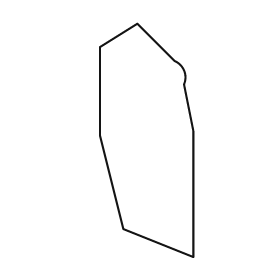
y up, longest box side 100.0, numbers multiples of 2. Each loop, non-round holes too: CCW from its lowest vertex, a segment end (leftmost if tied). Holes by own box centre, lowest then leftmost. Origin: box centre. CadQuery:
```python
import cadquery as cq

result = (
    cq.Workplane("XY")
    .moveTo(20.0, -50.0)
    .lineTo(20.0, 4.0)
    .lineTo(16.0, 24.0)
    .threePointArc((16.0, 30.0), (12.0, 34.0))
    .lineTo(-4.0, 50.0)
    .lineTo(-20.0, 40.0)
    .lineTo(-20.0, 2.0)
    .lineTo(-10.0, -38.0)
    .close()
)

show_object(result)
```